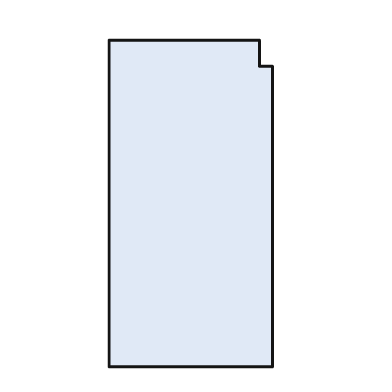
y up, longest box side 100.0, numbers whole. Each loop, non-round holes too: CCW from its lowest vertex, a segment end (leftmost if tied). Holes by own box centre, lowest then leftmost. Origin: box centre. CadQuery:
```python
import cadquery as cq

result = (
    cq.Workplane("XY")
    .moveTo(-25.0, -50.0)
    .lineTo(25.0, -50.0)
    .lineTo(25.0, 42.0)
    .lineTo(21.0, 42.0)
    .lineTo(21.0, 50.0)
    .lineTo(-25.0, 50.0)
    .close()
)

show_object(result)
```